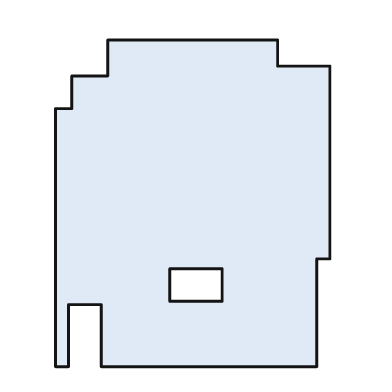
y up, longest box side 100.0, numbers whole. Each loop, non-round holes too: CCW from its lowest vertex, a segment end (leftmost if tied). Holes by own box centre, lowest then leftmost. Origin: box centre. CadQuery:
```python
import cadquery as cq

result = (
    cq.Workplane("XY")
    .moveTo(-42.0, -50.0)
    .lineTo(-38.0, -50.0)
    .lineTo(-38.0, -31.0)
    .lineTo(-28.0, -31.0)
    .lineTo(-28.0, -50.0)
    .lineTo(38.0, -50.0)
    .lineTo(38.0, -17.0)
    .lineTo(42.0, -17.0)
    .lineTo(42.0, 42.0)
    .lineTo(26.0, 42.0)
    .lineTo(26.0, 50.0)
    .lineTo(-26.0, 50.0)
    .lineTo(-26.0, 39.0)
    .lineTo(-37.0, 39.0)
    .lineTo(-37.0, 29.0)
    .lineTo(-42.0, 29.0)
    .close()
    .moveTo(-7.0, -30.0)
    .lineTo(9.0, -30.0)
    .lineTo(9.0, -20.0)
    .lineTo(-7.0, -20.0)
    .close()
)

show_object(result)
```